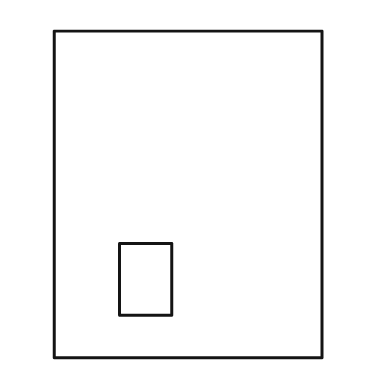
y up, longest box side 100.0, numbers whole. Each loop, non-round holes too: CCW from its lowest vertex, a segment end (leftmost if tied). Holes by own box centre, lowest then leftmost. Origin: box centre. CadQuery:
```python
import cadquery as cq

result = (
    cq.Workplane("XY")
    .moveTo(-41.0, -50.0)
    .lineTo(41.0, -50.0)
    .lineTo(41.0, 50.0)
    .lineTo(-41.0, 50.0)
    .close()
    .moveTo(-21.0, -37.0)
    .lineTo(-5.0, -37.0)
    .lineTo(-5.0, -15.0)
    .lineTo(-21.0, -15.0)
    .close()
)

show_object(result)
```